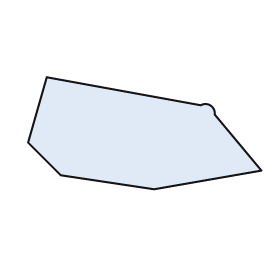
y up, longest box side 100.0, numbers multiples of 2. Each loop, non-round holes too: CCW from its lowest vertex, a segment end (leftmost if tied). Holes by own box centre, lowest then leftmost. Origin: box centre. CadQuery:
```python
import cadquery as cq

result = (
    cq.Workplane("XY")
    .moveTo(4.0, -24.0)
    .lineTo(50.0, -16.0)
    .lineTo(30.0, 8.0)
    .threePointArc((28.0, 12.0), (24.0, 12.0))
    .lineTo(-42.0, 24.0)
    .lineTo(-50.0, -4.0)
    .lineTo(-36.0, -18.0)
    .close()
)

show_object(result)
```